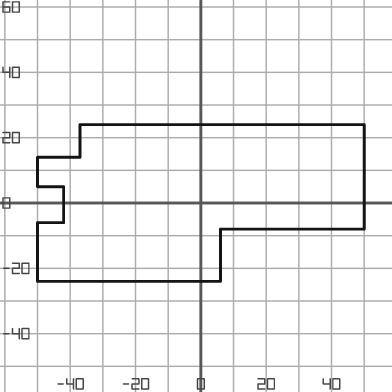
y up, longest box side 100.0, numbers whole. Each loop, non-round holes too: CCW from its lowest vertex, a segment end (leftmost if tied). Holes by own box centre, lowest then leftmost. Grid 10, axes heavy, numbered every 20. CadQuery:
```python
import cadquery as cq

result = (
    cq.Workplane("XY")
    .moveTo(-50.0, -24.0)
    .lineTo(6.0, -24.0)
    .lineTo(6.0, -8.0)
    .lineTo(50.0, -8.0)
    .lineTo(50.0, 24.0)
    .lineTo(-37.0, 24.0)
    .lineTo(-37.0, 14.0)
    .lineTo(-50.0, 14.0)
    .lineTo(-50.0, 5.0)
    .lineTo(-42.0, 5.0)
    .lineTo(-42.0, -6.0)
    .lineTo(-50.0, -6.0)
    .close()
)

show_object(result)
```